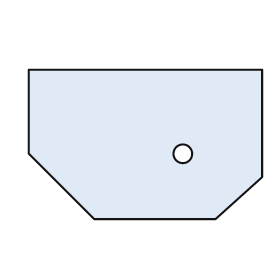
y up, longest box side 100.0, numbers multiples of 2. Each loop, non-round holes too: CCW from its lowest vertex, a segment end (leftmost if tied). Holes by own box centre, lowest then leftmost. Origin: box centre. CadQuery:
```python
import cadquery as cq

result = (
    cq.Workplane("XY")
    .moveTo(-22.0, -32.0)
    .lineTo(30.0, -32.0)
    .lineTo(50.0, -14.0)
    .lineTo(50.0, 32.0)
    .lineTo(-50.0, 32.0)
    .lineTo(-50.0, -4.0)
    .close()
    .moveTo(16.0, -4.0)
    .circle(4.0)
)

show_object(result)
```